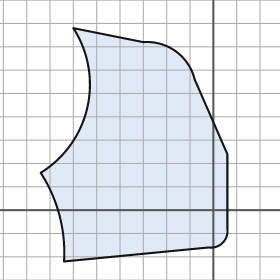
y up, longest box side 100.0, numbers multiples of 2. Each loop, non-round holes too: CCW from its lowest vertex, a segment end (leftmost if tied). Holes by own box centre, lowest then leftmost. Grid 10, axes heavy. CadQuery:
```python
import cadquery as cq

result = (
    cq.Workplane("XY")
    .moveTo(-64.0, -22.0)
    .lineTo(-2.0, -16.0)
    .threePointArc((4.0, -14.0), (6.0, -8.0))
    .lineTo(6.0, 24.0)
    .lineTo(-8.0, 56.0)
    .threePointArc((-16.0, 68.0), (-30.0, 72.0))
    .lineTo(-60.0, 78.0)
    .threePointArc((-54.0, 44.0), (-74.0, 16.0))
    .threePointArc((-66.0, -2.0), (-64.0, -22.0))
    .close()
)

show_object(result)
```